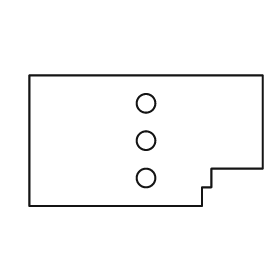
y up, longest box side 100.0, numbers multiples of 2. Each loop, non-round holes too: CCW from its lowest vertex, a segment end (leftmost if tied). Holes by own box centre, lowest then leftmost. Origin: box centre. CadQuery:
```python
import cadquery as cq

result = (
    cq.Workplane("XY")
    .moveTo(-50.0, -28.0)
    .lineTo(24.0, -28.0)
    .lineTo(24.0, -20.0)
    .lineTo(28.0, -20.0)
    .lineTo(28.0, -12.0)
    .lineTo(50.0, -12.0)
    .lineTo(50.0, 28.0)
    .lineTo(-50.0, 28.0)
    .close()
    .moveTo(0.0, -16.0)
    .circle(4.0)
    .moveTo(0.0, 0.0)
    .circle(4.0)
    .moveTo(0.0, 16.0)
    .circle(4.0)
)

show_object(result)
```